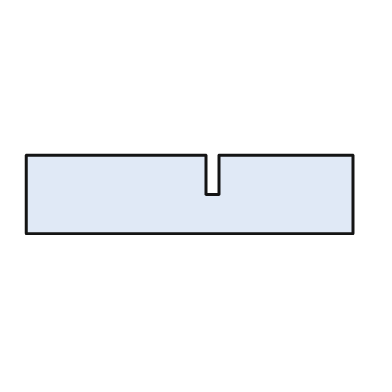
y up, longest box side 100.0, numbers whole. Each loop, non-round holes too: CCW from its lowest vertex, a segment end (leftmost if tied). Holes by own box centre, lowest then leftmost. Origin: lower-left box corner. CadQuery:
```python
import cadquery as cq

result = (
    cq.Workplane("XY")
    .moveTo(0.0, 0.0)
    .lineTo(100.0, 0.0)
    .lineTo(100.0, 24.0)
    .lineTo(59.0, 24.0)
    .lineTo(59.0, 12.0)
    .lineTo(55.0, 12.0)
    .lineTo(55.0, 24.0)
    .lineTo(0.0, 24.0)
    .close()
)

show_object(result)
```